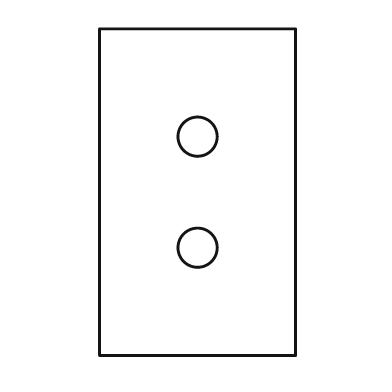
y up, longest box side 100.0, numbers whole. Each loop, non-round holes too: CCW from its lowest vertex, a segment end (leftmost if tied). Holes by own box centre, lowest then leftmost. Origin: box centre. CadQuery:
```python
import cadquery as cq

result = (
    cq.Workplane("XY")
    .moveTo(-30.0, -50.0)
    .lineTo(30.0, -50.0)
    .lineTo(30.0, 50.0)
    .lineTo(-30.0, 50.0)
    .close()
    .moveTo(0.0, -17.0)
    .circle(6.0)
    .moveTo(0.0, 17.0)
    .circle(6.0)
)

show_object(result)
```